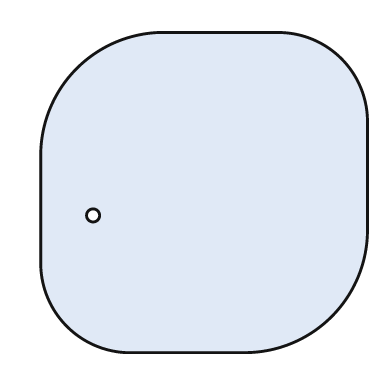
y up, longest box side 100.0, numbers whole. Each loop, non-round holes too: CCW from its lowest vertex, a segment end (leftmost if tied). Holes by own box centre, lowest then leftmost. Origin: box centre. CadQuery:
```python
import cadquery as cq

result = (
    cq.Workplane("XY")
    .moveTo(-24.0, -49.0)
    .lineTo(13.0, -49.0)
    .threePointArc((39.0, -38.0), (50.0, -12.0))
    .lineTo(50.0, 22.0)
    .threePointArc((42.0, 41.0), (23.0, 49.0))
    .lineTo(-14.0, 49.0)
    .threePointArc((-39.0, 38.0), (-50.0, 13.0))
    .lineTo(-50.0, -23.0)
    .threePointArc((-42.0, -41.0), (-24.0, -49.0))
    .close()
    .moveTo(-34.0, -7.0)
    .circle(2.0)
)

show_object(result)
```